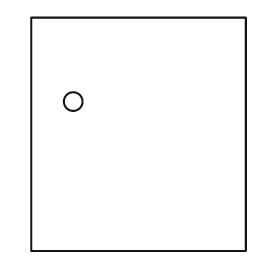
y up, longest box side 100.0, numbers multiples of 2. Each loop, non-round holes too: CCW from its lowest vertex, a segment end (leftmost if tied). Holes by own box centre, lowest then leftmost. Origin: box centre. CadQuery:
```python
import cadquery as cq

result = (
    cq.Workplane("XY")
    .moveTo(-46.0, -50.0)
    .lineTo(46.0, -50.0)
    .lineTo(46.0, 50.0)
    .lineTo(-46.0, 50.0)
    .close()
    .moveTo(-28.0, 14.0)
    .circle(4.0)
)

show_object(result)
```